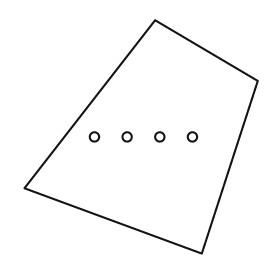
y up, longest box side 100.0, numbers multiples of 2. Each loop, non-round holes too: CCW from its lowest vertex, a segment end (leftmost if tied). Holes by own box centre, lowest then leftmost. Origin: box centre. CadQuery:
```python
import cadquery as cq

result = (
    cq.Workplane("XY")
    .moveTo(26.0, -50.0)
    .lineTo(50.0, 24.0)
    .lineTo(6.0, 50.0)
    .lineTo(-50.0, -22.0)
    .close()
    .moveTo(-20.0, 0.0)
    .circle(2.0)
    .moveTo(-6.0, 0.0)
    .circle(2.0)
    .moveTo(8.0, 0.0)
    .circle(2.0)
    .moveTo(22.0, 0.0)
    .circle(2.0)
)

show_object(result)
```